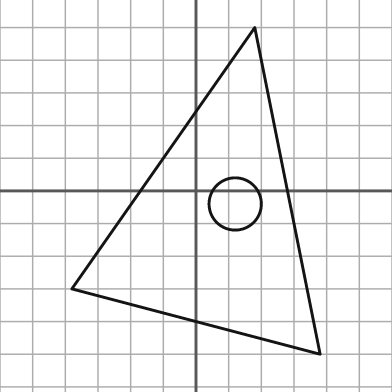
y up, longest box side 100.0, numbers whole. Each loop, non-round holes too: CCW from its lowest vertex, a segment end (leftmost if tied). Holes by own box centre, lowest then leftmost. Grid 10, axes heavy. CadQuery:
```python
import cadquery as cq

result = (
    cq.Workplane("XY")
    .moveTo(38.0, -50.0)
    .lineTo(18.0, 50.0)
    .lineTo(-38.0, -30.0)
    .close()
    .moveTo(12.0, -4.0)
    .circle(8.0)
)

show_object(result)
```